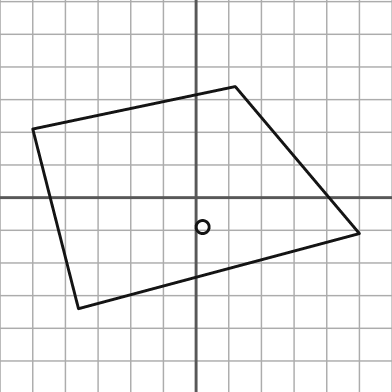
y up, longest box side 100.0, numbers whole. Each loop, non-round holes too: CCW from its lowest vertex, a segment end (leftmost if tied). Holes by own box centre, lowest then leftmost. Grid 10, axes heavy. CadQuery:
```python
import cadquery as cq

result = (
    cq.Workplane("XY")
    .moveTo(-36.0, -34.0)
    .lineTo(50.0, -11.0)
    .lineTo(12.0, 34.0)
    .lineTo(-50.0, 21.0)
    .close()
    .moveTo(2.0, -9.0)
    .circle(2.0)
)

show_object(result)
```